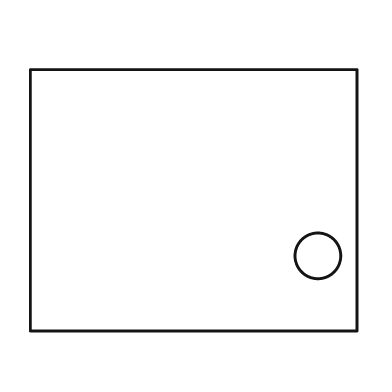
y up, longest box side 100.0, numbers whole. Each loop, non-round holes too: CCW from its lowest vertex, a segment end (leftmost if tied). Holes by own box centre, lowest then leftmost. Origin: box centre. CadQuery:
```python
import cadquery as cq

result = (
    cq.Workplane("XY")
    .moveTo(-50.0, -40.0)
    .lineTo(50.0, -40.0)
    .lineTo(50.0, 40.0)
    .lineTo(-50.0, 40.0)
    .close()
    .moveTo(38.0, -17.0)
    .circle(7.0)
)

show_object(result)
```